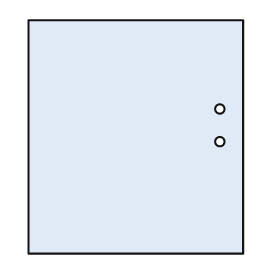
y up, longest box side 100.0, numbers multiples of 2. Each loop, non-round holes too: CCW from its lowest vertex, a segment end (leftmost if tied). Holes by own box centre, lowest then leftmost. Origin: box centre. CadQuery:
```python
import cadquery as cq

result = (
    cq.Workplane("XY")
    .moveTo(-46.0, -50.0)
    .lineTo(46.0, -50.0)
    .lineTo(46.0, 50.0)
    .lineTo(-46.0, 50.0)
    .close()
    .moveTo(36.0, -2.0)
    .circle(2.0)
    .moveTo(36.0, 12.0)
    .circle(2.0)
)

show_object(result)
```